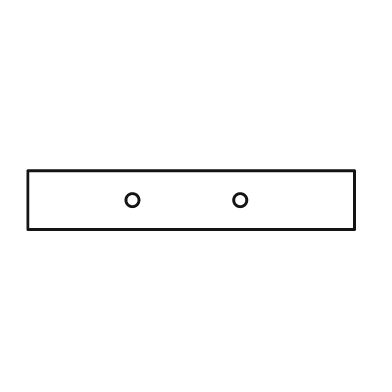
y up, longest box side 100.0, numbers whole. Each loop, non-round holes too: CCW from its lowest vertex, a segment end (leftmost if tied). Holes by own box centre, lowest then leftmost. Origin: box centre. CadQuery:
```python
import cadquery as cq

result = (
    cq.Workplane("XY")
    .moveTo(-50.0, -9.0)
    .lineTo(50.0, -9.0)
    .lineTo(50.0, 9.0)
    .lineTo(-50.0, 9.0)
    .close()
    .moveTo(-18.0, 0.0)
    .circle(2.0)
    .moveTo(15.0, 0.0)
    .circle(2.0)
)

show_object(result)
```